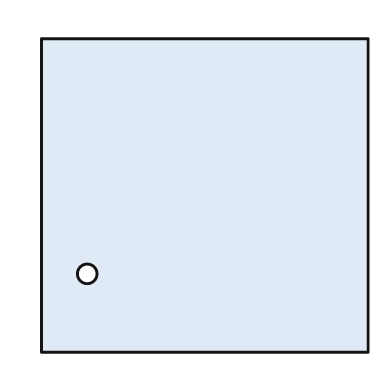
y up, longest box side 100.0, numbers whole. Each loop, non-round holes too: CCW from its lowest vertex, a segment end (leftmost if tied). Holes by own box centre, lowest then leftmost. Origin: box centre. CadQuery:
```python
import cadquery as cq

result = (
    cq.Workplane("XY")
    .moveTo(-50.0, -48.0)
    .lineTo(50.0, -48.0)
    .lineTo(50.0, 48.0)
    .lineTo(-50.0, 48.0)
    .close()
    .moveTo(-36.0, -24.0)
    .circle(3.0)
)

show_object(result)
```